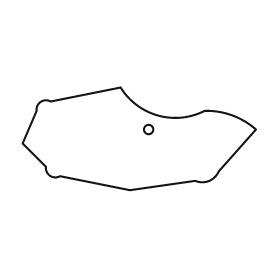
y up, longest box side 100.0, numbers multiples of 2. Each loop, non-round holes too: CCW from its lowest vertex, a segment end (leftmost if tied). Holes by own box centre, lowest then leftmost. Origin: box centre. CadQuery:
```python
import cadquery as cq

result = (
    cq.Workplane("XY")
    .moveTo(-4.0, -22.0)
    .lineTo(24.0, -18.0)
    .threePointArc((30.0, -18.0), (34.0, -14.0))
    .lineTo(50.0, 4.0)
    .threePointArc((40.0, 10.0), (28.0, 12.0))
    .threePointArc((8.0, 10.0), (-8.0, 22.0))
    .lineTo(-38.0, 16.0)
    .threePointArc((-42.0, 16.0), (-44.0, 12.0))
    .lineTo(-50.0, -2.0)
    .lineTo(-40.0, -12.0)
    .threePointArc((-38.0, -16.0), (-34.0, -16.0))
    .close()
    .moveTo(4.0, 4.0)
    .circle(2.0)
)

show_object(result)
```